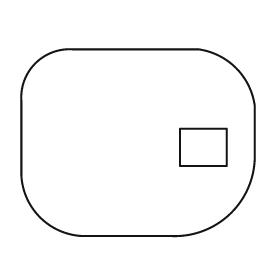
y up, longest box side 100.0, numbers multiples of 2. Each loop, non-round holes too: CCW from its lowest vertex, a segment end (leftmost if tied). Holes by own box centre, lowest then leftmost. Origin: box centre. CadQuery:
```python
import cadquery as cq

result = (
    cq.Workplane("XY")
    .moveTo(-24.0, -40.0)
    .lineTo(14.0, -40.0)
    .threePointArc((40.0, -30.0), (50.0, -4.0))
    .lineTo(50.0, 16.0)
    .threePointArc((42.0, 32.0), (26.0, 40.0))
    .lineTo(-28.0, 40.0)
    .threePointArc((-44.0, 34.0), (-50.0, 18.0))
    .lineTo(-50.0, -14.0)
    .threePointArc((-42.0, -32.0), (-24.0, -40.0))
    .close()
    .moveTo(18.0, -10.0)
    .lineTo(38.0, -10.0)
    .lineTo(38.0, 6.0)
    .lineTo(18.0, 6.0)
    .close()
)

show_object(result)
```